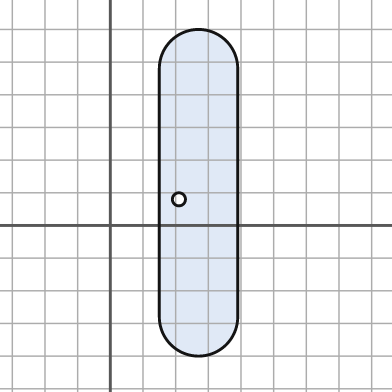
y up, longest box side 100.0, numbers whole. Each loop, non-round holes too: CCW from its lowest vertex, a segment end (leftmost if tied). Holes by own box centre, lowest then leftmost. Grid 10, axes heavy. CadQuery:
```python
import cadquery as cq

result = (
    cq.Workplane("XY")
    .moveTo(15.0, -28.0)
    .threePointArc((27.0, -40.0), (39.0, -28.0))
    .lineTo(39.0, 48.0)
    .threePointArc((27.0, 60.0), (15.0, 48.0))
    .close()
    .moveTo(21.0, 8.0)
    .circle(2.0)
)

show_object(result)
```